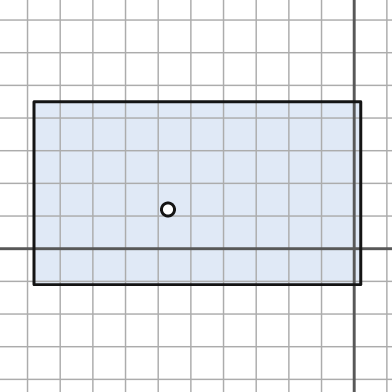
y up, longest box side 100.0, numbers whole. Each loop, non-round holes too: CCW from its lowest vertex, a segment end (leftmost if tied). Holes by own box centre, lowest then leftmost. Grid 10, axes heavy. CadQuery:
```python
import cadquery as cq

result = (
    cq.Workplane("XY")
    .moveTo(-98.0, -11.0)
    .lineTo(2.0, -11.0)
    .lineTo(2.0, 45.0)
    .lineTo(-98.0, 45.0)
    .close()
    .moveTo(-57.0, 12.0)
    .circle(2.0)
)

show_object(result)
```